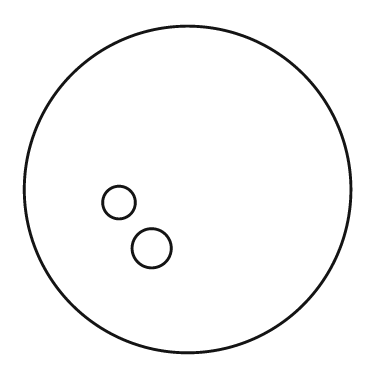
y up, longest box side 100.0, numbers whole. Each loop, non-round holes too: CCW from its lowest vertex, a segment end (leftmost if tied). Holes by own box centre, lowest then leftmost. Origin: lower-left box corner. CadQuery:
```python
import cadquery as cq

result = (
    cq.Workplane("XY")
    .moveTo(50.0, 50.0)
    .circle(50.0)
    .moveTo(39.0, 32.0)
    .circle(6.0)
    .moveTo(29.0, 46.0)
    .circle(5.0)
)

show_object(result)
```